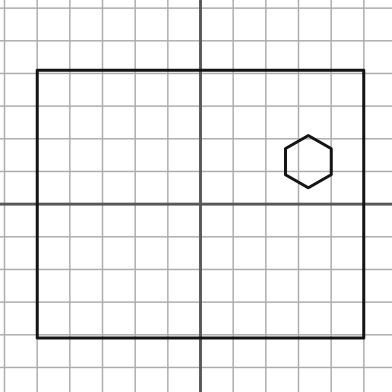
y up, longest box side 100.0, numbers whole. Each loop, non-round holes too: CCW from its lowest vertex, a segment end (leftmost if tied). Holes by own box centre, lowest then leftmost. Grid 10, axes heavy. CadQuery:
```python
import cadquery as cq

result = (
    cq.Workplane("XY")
    .moveTo(-50.0, -41.0)
    .lineTo(50.0, -41.0)
    .lineTo(50.0, 41.0)
    .lineTo(-50.0, 41.0)
    .close()
    .moveTo(33.0, 5.0)
    .lineTo(40.0, 9.0)
    .lineTo(40.0, 17.0)
    .lineTo(33.0, 21.0)
    .lineTo(26.0, 17.0)
    .lineTo(26.0, 9.0)
    .close()
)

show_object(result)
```